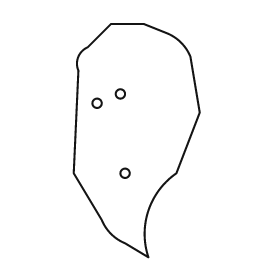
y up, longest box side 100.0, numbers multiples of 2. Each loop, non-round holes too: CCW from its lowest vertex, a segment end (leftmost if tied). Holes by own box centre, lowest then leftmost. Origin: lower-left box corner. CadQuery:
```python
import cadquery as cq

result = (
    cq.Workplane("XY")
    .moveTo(32.0, 0.0)
    .threePointArc((32.0, 20.0), (44.0, 36.0))
    .lineTo(54.0, 62.0)
    .lineTo(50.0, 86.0)
    .threePointArc((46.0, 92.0), (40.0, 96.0))
    .lineTo(30.0, 100.0)
    .lineTo(16.0, 100.0)
    .lineTo(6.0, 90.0)
    .threePointArc((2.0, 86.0), (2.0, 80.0))
    .lineTo(0.0, 36.0)
    .lineTo(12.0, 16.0)
    .threePointArc((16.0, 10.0), (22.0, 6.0))
    .close()
    .moveTo(22.0, 36.0)
    .circle(2.0)
    .moveTo(10.0, 66.0)
    .circle(2.0)
    .moveTo(20.0, 70.0)
    .circle(2.0)
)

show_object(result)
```